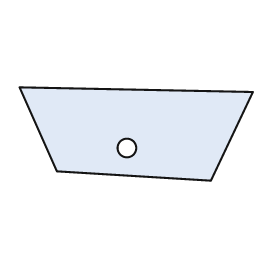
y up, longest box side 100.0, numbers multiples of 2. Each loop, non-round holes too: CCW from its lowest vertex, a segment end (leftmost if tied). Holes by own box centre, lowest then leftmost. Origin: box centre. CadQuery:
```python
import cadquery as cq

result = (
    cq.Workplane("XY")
    .moveTo(32.0, -20.0)
    .lineTo(50.0, 18.0)
    .lineTo(-50.0, 20.0)
    .lineTo(-34.0, -16.0)
    .close()
    .moveTo(-4.0, -6.0)
    .circle(4.0)
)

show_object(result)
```